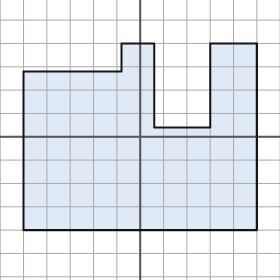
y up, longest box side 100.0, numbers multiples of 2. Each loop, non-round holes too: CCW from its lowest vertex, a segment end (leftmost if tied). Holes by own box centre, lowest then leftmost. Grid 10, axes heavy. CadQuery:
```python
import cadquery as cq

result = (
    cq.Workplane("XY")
    .moveTo(-50.0, -40.0)
    .lineTo(50.0, -40.0)
    .lineTo(50.0, 40.0)
    .lineTo(30.0, 40.0)
    .lineTo(30.0, 4.0)
    .lineTo(6.0, 4.0)
    .lineTo(6.0, 40.0)
    .lineTo(-8.0, 40.0)
    .lineTo(-8.0, 28.0)
    .lineTo(-50.0, 28.0)
    .close()
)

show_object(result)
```